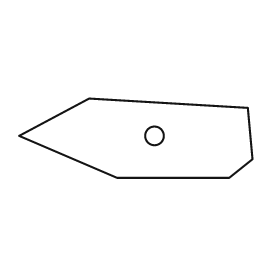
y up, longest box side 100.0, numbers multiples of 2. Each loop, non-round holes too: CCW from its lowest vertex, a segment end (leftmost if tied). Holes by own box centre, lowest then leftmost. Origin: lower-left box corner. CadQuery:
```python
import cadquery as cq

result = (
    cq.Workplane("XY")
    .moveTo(42.0, 0.0)
    .lineTo(90.0, 0.0)
    .lineTo(100.0, 8.0)
    .lineTo(98.0, 30.0)
    .lineTo(30.0, 34.0)
    .lineTo(0.0, 18.0)
    .close()
    .moveTo(58.0, 18.0)
    .circle(4.0)
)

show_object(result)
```